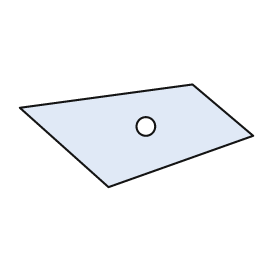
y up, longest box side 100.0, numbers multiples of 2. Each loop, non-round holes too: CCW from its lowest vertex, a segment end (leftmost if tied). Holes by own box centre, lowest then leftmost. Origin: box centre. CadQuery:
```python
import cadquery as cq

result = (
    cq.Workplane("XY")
    .moveTo(-12.0, -22.0)
    .lineTo(50.0, 0.0)
    .lineTo(24.0, 22.0)
    .lineTo(-50.0, 12.0)
    .close()
    .moveTo(4.0, 4.0)
    .circle(4.0)
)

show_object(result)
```